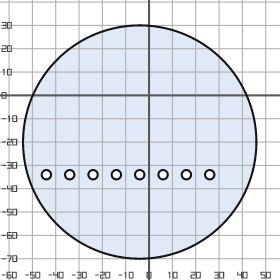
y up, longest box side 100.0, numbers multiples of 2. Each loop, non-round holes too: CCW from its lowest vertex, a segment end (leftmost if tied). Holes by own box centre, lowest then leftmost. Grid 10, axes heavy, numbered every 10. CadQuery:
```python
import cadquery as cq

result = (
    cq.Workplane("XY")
    .moveTo(-4.0, -20.0)
    .circle(50.0)
    .moveTo(-44.0, -34.0)
    .circle(2.0)
    .moveTo(-34.0, -34.0)
    .circle(2.0)
    .moveTo(-24.0, -34.0)
    .circle(2.0)
    .moveTo(-14.0, -34.0)
    .circle(2.0)
    .moveTo(-4.0, -34.0)
    .circle(2.0)
    .moveTo(6.0, -34.0)
    .circle(2.0)
    .moveTo(16.0, -34.0)
    .circle(2.0)
    .moveTo(26.0, -34.0)
    .circle(2.0)
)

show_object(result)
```